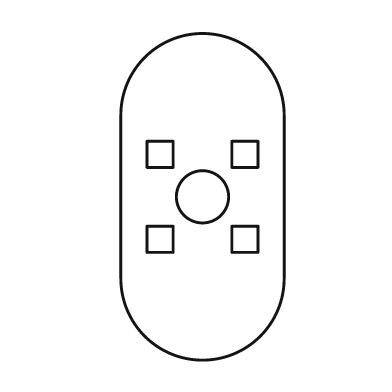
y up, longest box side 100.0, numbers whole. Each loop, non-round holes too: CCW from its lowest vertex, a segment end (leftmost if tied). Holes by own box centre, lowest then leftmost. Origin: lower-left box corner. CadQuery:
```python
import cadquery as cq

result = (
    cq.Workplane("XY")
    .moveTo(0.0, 25.0)
    .threePointArc((25.0, 0.0), (50.0, 25.0))
    .lineTo(50.0, 75.0)
    .threePointArc((25.0, 100.0), (0.0, 75.0))
    .close()
    .moveTo(8.0, 33.0)
    .lineTo(16.0, 33.0)
    .lineTo(16.0, 41.0)
    .lineTo(8.0, 41.0)
    .close()
    .moveTo(34.0, 33.0)
    .lineTo(42.0, 33.0)
    .lineTo(42.0, 41.0)
    .lineTo(34.0, 41.0)
    .close()
    .moveTo(25.0, 50.0)
    .circle(8.0)
    .moveTo(8.0, 59.0)
    .lineTo(16.0, 59.0)
    .lineTo(16.0, 67.0)
    .lineTo(8.0, 67.0)
    .close()
    .moveTo(34.0, 59.0)
    .lineTo(42.0, 59.0)
    .lineTo(42.0, 67.0)
    .lineTo(34.0, 67.0)
    .close()
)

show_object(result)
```